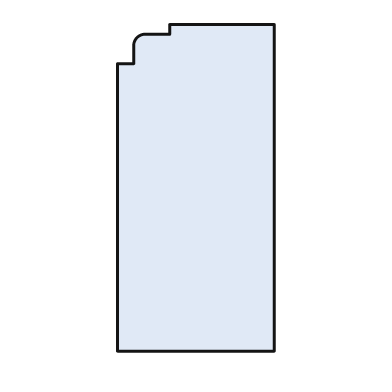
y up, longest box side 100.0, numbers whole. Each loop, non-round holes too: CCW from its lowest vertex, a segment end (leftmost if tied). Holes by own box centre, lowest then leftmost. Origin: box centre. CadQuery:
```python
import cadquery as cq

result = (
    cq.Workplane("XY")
    .moveTo(-24.0, -50.0)
    .lineTo(24.0, -50.0)
    .lineTo(24.0, 50.0)
    .lineTo(-8.0, 50.0)
    .lineTo(-8.0, 47.0)
    .lineTo(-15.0, 47.0)
    .threePointArc((-18.0, 46.0), (-19.0, 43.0))
    .lineTo(-19.0, 38.0)
    .lineTo(-24.0, 38.0)
    .close()
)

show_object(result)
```